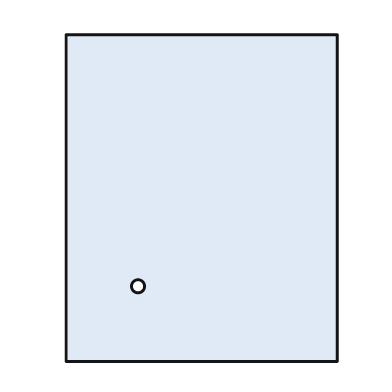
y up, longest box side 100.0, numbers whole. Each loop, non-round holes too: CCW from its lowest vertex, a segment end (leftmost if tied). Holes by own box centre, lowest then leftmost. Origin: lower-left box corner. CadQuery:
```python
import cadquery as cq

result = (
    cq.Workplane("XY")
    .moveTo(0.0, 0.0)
    .lineTo(83.0, 0.0)
    .lineTo(83.0, 100.0)
    .lineTo(0.0, 100.0)
    .close()
    .moveTo(22.0, 23.0)
    .circle(2.0)
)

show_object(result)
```